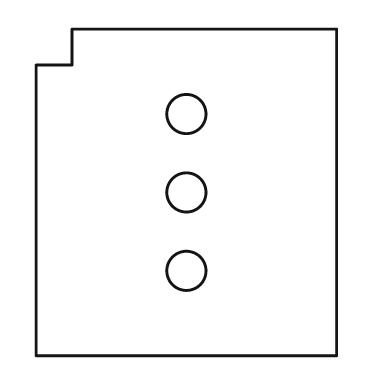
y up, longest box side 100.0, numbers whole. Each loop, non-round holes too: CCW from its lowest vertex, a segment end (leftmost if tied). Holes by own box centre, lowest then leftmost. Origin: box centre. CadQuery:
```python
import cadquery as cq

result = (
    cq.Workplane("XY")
    .moveTo(-46.0, -50.0)
    .lineTo(46.0, -50.0)
    .lineTo(46.0, 50.0)
    .lineTo(-35.0, 50.0)
    .lineTo(-35.0, 39.0)
    .lineTo(-46.0, 39.0)
    .close()
    .moveTo(0.0, -24.0)
    .circle(6.0)
    .moveTo(0.0, 0.0)
    .circle(6.0)
    .moveTo(0.0, 24.0)
    .circle(6.0)
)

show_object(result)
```